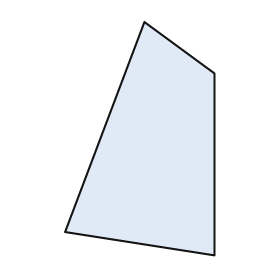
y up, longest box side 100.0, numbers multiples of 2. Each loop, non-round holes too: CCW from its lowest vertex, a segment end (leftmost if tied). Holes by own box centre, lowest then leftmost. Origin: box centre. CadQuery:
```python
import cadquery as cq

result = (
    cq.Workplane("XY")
    .moveTo(32.0, -50.0)
    .lineTo(32.0, 28.0)
    .lineTo(2.0, 50.0)
    .lineTo(-32.0, -40.0)
    .close()
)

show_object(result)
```